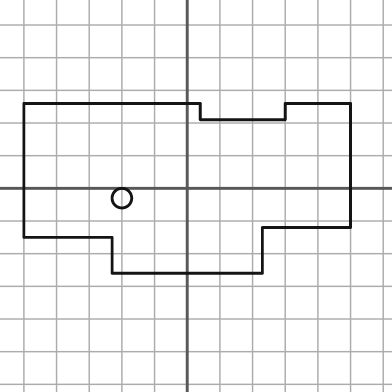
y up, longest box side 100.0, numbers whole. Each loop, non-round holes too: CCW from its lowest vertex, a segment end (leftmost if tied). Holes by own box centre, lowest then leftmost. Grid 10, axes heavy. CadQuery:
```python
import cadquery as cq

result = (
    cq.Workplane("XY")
    .moveTo(-23.0, -26.0)
    .lineTo(23.0, -26.0)
    .lineTo(23.0, -12.0)
    .lineTo(50.0, -12.0)
    .lineTo(50.0, 26.0)
    .lineTo(30.0, 26.0)
    .lineTo(30.0, 21.0)
    .lineTo(4.0, 21.0)
    .lineTo(4.0, 26.0)
    .lineTo(-50.0, 26.0)
    .lineTo(-50.0, -15.0)
    .lineTo(-23.0, -15.0)
    .close()
    .moveTo(-20.0, -3.0)
    .circle(3.0)
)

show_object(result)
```